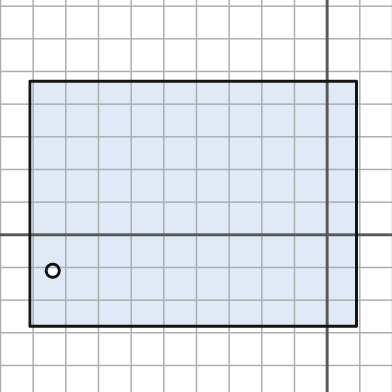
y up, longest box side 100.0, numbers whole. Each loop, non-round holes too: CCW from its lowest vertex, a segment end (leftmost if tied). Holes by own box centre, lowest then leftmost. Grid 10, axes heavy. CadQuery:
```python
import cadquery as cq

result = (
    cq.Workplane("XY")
    .moveTo(-91.0, -28.0)
    .lineTo(9.0, -28.0)
    .lineTo(9.0, 47.0)
    .lineTo(-91.0, 47.0)
    .close()
    .moveTo(-84.0, -11.0)
    .circle(2.0)
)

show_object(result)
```